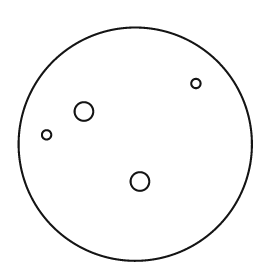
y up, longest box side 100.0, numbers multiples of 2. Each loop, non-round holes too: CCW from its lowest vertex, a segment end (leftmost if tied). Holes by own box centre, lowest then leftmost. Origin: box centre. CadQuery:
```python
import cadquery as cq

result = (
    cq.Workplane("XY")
    .moveTo(0.0, 0.0)
    .circle(50.0)
    .moveTo(2.0, -16.0)
    .circle(4.0)
    .moveTo(-38.0, 4.0)
    .circle(2.0)
    .moveTo(-22.0, 14.0)
    .circle(4.0)
    .moveTo(26.0, 26.0)
    .circle(2.0)
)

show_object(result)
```